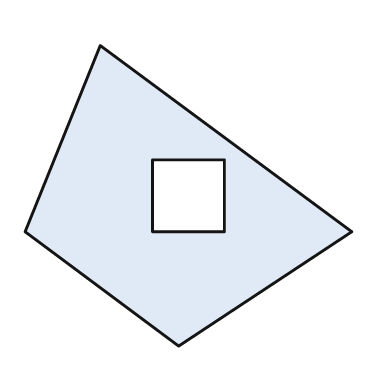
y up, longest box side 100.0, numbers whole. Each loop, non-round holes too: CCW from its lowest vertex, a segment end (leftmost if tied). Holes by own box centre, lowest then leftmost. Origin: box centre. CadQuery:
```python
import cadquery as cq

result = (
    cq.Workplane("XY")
    .moveTo(-3.0, -46.0)
    .lineTo(50.0, -11.0)
    .lineTo(-27.0, 46.0)
    .lineTo(-50.0, -11.0)
    .close()
    .moveTo(-11.0, -11.0)
    .lineTo(11.0, -11.0)
    .lineTo(11.0, 11.0)
    .lineTo(-11.0, 11.0)
    .close()
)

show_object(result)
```